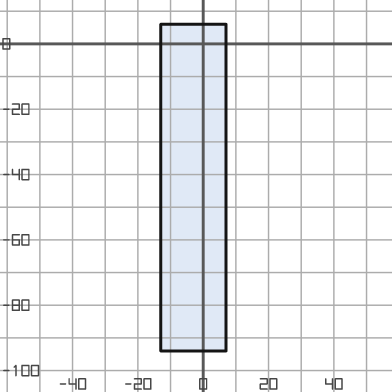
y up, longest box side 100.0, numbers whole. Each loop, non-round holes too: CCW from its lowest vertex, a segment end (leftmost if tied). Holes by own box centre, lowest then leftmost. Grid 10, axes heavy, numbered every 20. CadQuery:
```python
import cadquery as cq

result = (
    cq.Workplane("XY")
    .moveTo(-13.0, -94.0)
    .lineTo(7.0, -94.0)
    .lineTo(7.0, 6.0)
    .lineTo(-13.0, 6.0)
    .close()
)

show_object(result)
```